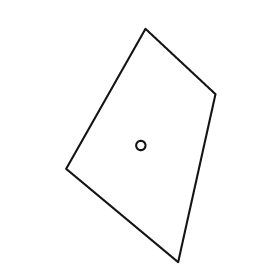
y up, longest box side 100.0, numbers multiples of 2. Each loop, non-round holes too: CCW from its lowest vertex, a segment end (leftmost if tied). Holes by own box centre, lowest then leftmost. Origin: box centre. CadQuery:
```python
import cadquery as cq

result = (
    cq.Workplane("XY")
    .moveTo(16.0, -50.0)
    .lineTo(32.0, 22.0)
    .lineTo(2.0, 50.0)
    .lineTo(-32.0, -10.0)
    .close()
    .moveTo(0.0, 0.0)
    .circle(2.0)
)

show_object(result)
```